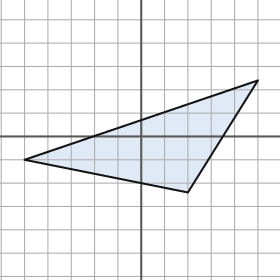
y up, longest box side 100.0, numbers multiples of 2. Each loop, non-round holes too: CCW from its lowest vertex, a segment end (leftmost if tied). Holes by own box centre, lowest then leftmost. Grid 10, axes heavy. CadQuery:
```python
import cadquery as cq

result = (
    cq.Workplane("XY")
    .moveTo(20.0, -24.0)
    .lineTo(50.0, 24.0)
    .lineTo(-50.0, -10.0)
    .close()
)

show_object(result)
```